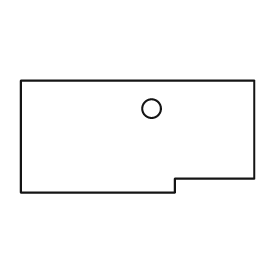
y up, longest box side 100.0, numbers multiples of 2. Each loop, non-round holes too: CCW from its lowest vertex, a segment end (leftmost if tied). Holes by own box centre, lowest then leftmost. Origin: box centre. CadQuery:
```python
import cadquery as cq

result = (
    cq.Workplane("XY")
    .moveTo(-50.0, -24.0)
    .lineTo(16.0, -24.0)
    .lineTo(16.0, -18.0)
    .lineTo(50.0, -18.0)
    .lineTo(50.0, 24.0)
    .lineTo(-50.0, 24.0)
    .close()
    .moveTo(6.0, 12.0)
    .circle(4.0)
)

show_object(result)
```